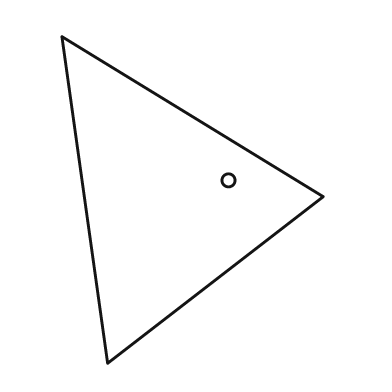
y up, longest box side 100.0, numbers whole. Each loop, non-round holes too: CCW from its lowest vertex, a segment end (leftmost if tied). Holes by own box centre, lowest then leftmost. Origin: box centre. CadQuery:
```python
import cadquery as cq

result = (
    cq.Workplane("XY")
    .moveTo(-26.0, -50.0)
    .lineTo(40.0, 1.0)
    .lineTo(-40.0, 50.0)
    .close()
    .moveTo(11.0, 6.0)
    .circle(2.0)
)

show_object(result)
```